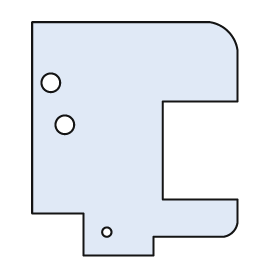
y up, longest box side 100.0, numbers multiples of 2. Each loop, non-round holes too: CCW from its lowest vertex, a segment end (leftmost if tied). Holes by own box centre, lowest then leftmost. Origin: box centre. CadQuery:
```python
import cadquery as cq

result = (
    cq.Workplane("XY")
    .moveTo(-22.0, -50.0)
    .lineTo(8.0, -50.0)
    .lineTo(8.0, -42.0)
    .lineTo(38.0, -42.0)
    .threePointArc((42.0, -40.0), (44.0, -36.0))
    .lineTo(44.0, -26.0)
    .lineTo(12.0, -26.0)
    .lineTo(12.0, 16.0)
    .lineTo(44.0, 16.0)
    .lineTo(44.0, 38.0)
    .threePointArc((40.0, 46.0), (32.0, 50.0))
    .lineTo(-44.0, 50.0)
    .lineTo(-44.0, -32.0)
    .lineTo(-22.0, -32.0)
    .close()
    .moveTo(-12.0, -40.0)
    .circle(2.0)
    .moveTo(-30.0, 6.0)
    .circle(4.0)
    .moveTo(-36.0, 24.0)
    .circle(4.0)
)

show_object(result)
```